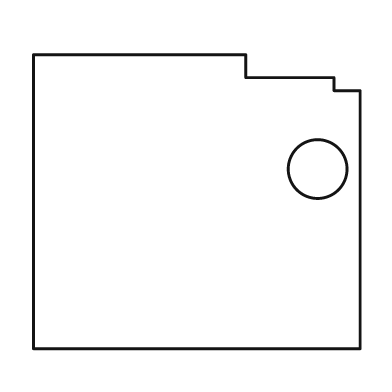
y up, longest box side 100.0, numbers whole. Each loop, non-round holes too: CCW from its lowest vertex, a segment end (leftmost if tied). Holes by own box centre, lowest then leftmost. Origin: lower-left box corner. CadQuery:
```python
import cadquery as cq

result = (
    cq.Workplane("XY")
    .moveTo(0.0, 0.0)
    .lineTo(100.0, 0.0)
    .lineTo(100.0, 79.0)
    .lineTo(92.0, 79.0)
    .lineTo(92.0, 83.0)
    .lineTo(65.0, 83.0)
    .lineTo(65.0, 90.0)
    .lineTo(0.0, 90.0)
    .close()
    .moveTo(87.0, 55.0)
    .circle(9.0)
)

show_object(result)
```